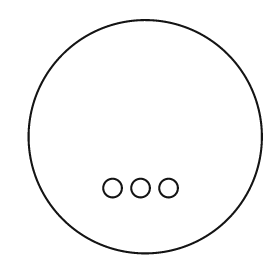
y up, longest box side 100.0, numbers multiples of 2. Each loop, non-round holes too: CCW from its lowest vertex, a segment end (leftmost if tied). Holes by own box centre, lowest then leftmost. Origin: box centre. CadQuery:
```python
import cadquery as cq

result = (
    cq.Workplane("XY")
    .moveTo(0.0, 0.0)
    .circle(50.0)
    .moveTo(-14.0, -22.0)
    .circle(4.0)
    .moveTo(-2.0, -22.0)
    .circle(4.0)
    .moveTo(10.0, -22.0)
    .circle(4.0)
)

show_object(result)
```